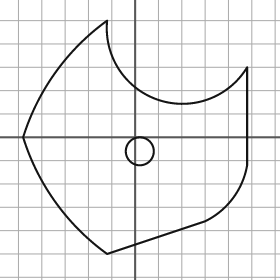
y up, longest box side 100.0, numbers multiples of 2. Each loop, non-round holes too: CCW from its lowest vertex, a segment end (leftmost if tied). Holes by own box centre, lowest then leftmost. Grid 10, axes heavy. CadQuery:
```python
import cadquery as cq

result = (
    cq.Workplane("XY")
    .moveTo(-12.0, -50.0)
    .lineTo(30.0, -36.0)
    .threePointArc((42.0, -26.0), (48.0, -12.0))
    .lineTo(48.0, 30.0)
    .threePointArc((10.0, 16.0), (-12.0, 50.0))
    .threePointArc((-34.0, 28.0), (-48.0, 0.0))
    .threePointArc((-34.0, -28.0), (-12.0, -50.0))
    .close()
    .moveTo(2.0, -6.0)
    .circle(6.0)
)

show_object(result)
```